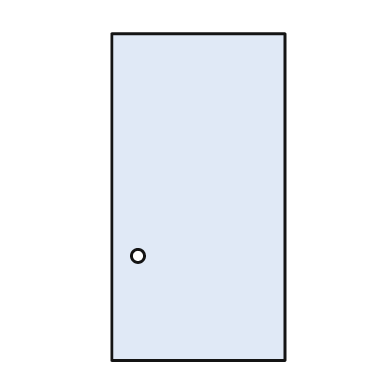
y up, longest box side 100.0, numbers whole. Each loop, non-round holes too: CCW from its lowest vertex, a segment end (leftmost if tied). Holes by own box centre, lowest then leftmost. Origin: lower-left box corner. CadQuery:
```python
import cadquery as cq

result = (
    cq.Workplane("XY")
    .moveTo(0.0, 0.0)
    .lineTo(53.0, 0.0)
    .lineTo(53.0, 100.0)
    .lineTo(0.0, 100.0)
    .close()
    .moveTo(8.0, 32.0)
    .circle(2.0)
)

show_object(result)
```